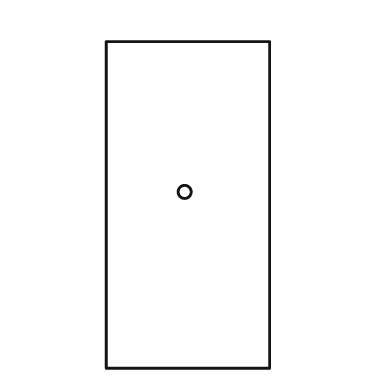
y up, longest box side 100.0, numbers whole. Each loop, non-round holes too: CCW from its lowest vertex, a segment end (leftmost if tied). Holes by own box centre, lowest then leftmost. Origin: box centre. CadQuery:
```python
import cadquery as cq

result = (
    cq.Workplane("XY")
    .moveTo(-25.0, -50.0)
    .lineTo(25.0, -50.0)
    .lineTo(25.0, 50.0)
    .lineTo(-25.0, 50.0)
    .close()
    .moveTo(-1.0, 4.0)
    .circle(2.0)
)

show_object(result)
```